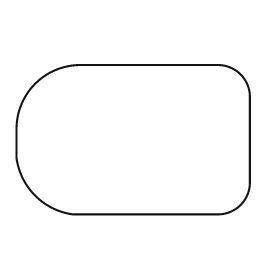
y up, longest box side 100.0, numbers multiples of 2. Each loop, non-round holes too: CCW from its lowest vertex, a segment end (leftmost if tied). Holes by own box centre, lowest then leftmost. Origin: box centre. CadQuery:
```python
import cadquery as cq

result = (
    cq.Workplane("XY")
    .moveTo(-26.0, -32.0)
    .lineTo(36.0, -32.0)
    .threePointArc((46.0, -28.0), (50.0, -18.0))
    .lineTo(50.0, 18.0)
    .threePointArc((46.0, 28.0), (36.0, 32.0))
    .lineTo(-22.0, 32.0)
    .threePointArc((-42.0, 24.0), (-50.0, 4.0))
    .lineTo(-50.0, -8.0)
    .threePointArc((-42.0, -24.0), (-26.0, -32.0))
    .close()
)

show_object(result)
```